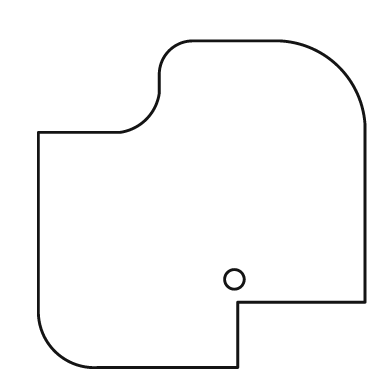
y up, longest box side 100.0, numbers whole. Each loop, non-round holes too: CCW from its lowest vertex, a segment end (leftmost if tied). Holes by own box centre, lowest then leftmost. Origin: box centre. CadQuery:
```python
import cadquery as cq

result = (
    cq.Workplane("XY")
    .moveTo(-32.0, -50.0)
    .lineTo(11.0, -50.0)
    .lineTo(11.0, -30.0)
    .lineTo(50.0, -30.0)
    .lineTo(50.0, 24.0)
    .threePointArc((42.0, 42.0), (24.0, 50.0))
    .lineTo(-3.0, 50.0)
    .threePointArc((-10.0, 47.0), (-13.0, 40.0))
    .lineTo(-13.0, 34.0)
    .threePointArc((-17.0, 26.0), (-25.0, 22.0))
    .lineTo(-50.0, 22.0)
    .lineTo(-50.0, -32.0)
    .threePointArc((-45.0, -45.0), (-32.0, -50.0))
    .close()
    .moveTo(10.0, -23.0)
    .circle(3.0)
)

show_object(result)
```